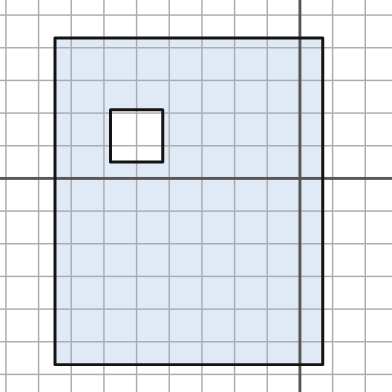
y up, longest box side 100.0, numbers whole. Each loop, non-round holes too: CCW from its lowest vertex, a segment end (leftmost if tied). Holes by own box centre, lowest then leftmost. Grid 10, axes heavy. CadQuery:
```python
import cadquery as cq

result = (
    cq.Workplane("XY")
    .moveTo(-75.0, -57.0)
    .lineTo(7.0, -57.0)
    .lineTo(7.0, 43.0)
    .lineTo(-75.0, 43.0)
    .close()
    .moveTo(-58.0, 5.0)
    .lineTo(-42.0, 5.0)
    .lineTo(-42.0, 21.0)
    .lineTo(-58.0, 21.0)
    .close()
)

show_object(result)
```